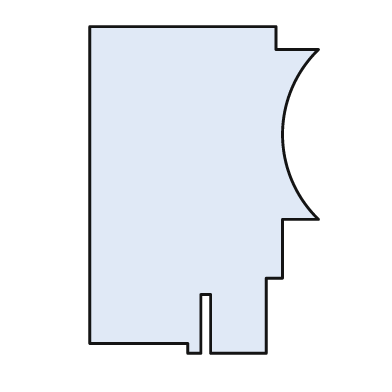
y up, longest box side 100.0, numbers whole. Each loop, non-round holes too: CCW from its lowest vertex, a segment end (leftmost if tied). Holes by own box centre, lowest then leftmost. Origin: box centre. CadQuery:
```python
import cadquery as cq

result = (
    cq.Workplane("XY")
    .moveTo(-5.0, -50.0)
    .lineTo(-1.0, -50.0)
    .lineTo(-1.0, -32.0)
    .lineTo(2.0, -32.0)
    .lineTo(2.0, -50.0)
    .lineTo(19.0, -50.0)
    .lineTo(19.0, -27.0)
    .lineTo(24.0, -27.0)
    .lineTo(24.0, -9.0)
    .lineTo(35.0, -9.0)
    .threePointArc((24.0, 17.0), (35.0, 43.0))
    .lineTo(22.0, 43.0)
    .lineTo(22.0, 50.0)
    .lineTo(-35.0, 50.0)
    .lineTo(-35.0, -47.0)
    .lineTo(-5.0, -47.0)
    .close()
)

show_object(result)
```